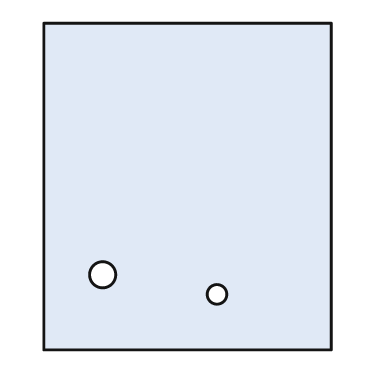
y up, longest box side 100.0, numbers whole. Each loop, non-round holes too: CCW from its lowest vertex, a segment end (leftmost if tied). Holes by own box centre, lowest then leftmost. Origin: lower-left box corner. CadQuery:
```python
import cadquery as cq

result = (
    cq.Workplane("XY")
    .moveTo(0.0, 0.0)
    .lineTo(88.0, 0.0)
    .lineTo(88.0, 100.0)
    .lineTo(0.0, 100.0)
    .close()
    .moveTo(53.0, 17.0)
    .circle(3.0)
    .moveTo(18.0, 23.0)
    .circle(4.0)
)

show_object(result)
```